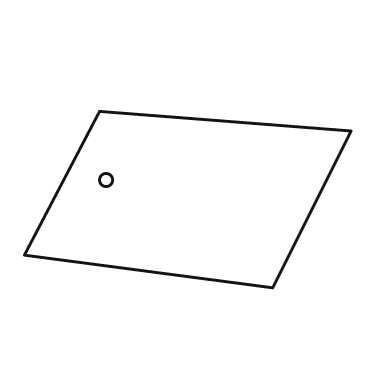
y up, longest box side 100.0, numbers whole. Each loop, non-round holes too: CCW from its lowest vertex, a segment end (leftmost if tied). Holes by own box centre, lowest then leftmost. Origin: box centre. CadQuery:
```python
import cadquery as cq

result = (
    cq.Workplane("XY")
    .moveTo(26.0, -27.0)
    .lineTo(50.0, 21.0)
    .lineTo(-27.0, 27.0)
    .lineTo(-50.0, -17.0)
    .close()
    .moveTo(-25.0, 6.0)
    .circle(2.0)
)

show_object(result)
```